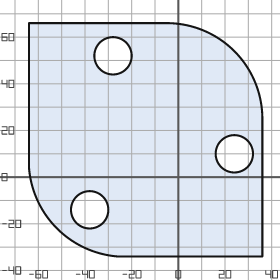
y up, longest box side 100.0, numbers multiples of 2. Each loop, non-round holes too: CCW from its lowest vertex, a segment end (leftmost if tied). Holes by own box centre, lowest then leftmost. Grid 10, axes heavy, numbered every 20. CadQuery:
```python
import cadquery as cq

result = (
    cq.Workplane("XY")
    .moveTo(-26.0, -34.0)
    .lineTo(36.0, -34.0)
    .lineTo(36.0, 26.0)
    .threePointArc((24.0, 54.0), (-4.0, 66.0))
    .lineTo(-64.0, 66.0)
    .lineTo(-64.0, 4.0)
    .threePointArc((-52.0, -22.0), (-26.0, -34.0))
    .close()
    .moveTo(-38.0, -14.0)
    .circle(8.0)
    .moveTo(24.0, 10.0)
    .circle(8.0)
    .moveTo(-28.0, 52.0)
    .circle(8.0)
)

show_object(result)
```